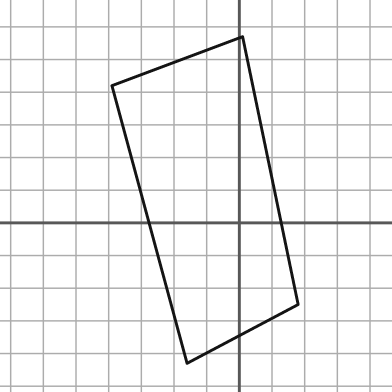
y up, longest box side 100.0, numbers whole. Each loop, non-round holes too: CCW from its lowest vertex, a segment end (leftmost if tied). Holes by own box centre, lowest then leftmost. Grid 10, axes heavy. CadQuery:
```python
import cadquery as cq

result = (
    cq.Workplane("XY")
    .moveTo(-16.0, -43.0)
    .lineTo(18.0, -25.0)
    .lineTo(1.0, 57.0)
    .lineTo(-39.0, 42.0)
    .close()
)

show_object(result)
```